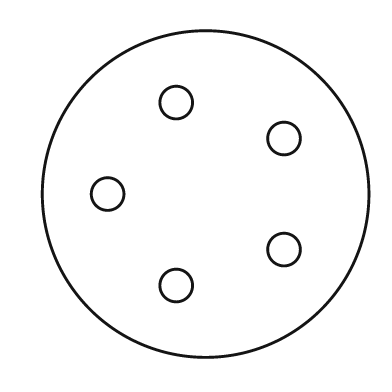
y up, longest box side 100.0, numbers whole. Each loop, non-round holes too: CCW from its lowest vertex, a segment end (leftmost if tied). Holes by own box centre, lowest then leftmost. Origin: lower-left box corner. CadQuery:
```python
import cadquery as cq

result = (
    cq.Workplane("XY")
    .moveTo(50.0, 50.0)
    .circle(50.0)
    .moveTo(41.0, 22.0)
    .circle(5.0)
    .moveTo(74.0, 33.0)
    .circle(5.0)
    .moveTo(20.0, 50.0)
    .circle(5.0)
    .moveTo(74.0, 67.0)
    .circle(5.0)
    .moveTo(41.0, 78.0)
    .circle(5.0)
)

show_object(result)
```